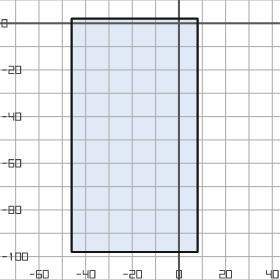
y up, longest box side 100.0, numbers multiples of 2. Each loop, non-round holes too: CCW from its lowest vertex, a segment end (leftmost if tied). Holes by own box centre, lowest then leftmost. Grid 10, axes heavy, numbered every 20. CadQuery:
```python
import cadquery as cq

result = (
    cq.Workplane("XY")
    .moveTo(-46.0, -98.0)
    .lineTo(8.0, -98.0)
    .lineTo(8.0, 2.0)
    .lineTo(-46.0, 2.0)
    .close()
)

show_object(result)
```